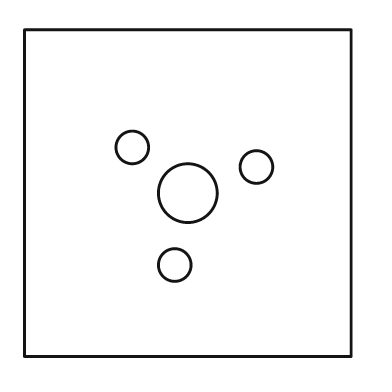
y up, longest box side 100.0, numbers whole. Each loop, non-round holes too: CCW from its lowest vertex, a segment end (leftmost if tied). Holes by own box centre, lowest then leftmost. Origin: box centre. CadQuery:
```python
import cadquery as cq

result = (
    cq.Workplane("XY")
    .moveTo(-50.0, -50.0)
    .lineTo(50.0, -50.0)
    .lineTo(50.0, 50.0)
    .lineTo(-50.0, 50.0)
    .close()
    .moveTo(-4.0, -22.0)
    .circle(5.0)
    .moveTo(0.0, 0.0)
    .circle(9.0)
    .moveTo(21.0, 8.0)
    .circle(5.0)
    .moveTo(-17.0, 14.0)
    .circle(5.0)
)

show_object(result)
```